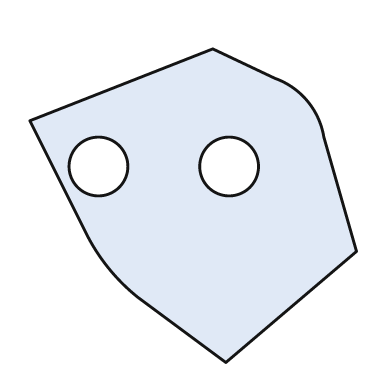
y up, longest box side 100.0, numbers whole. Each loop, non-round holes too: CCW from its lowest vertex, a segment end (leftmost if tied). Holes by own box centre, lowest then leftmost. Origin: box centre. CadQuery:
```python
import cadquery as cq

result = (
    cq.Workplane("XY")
    .moveTo(10.0, -48.0)
    .lineTo(50.0, -14.0)
    .lineTo(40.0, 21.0)
    .threePointArc((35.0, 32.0), (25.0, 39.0))
    .lineTo(6.0, 48.0)
    .lineTo(-50.0, 26.0)
    .lineTo(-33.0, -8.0)
    .threePointArc((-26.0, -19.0), (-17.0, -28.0))
    .close()
    .moveTo(-29.0, 12.0)
    .circle(9.0)
    .moveTo(11.0, 12.0)
    .circle(9.0)
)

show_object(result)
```